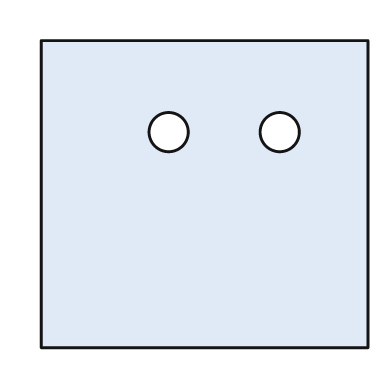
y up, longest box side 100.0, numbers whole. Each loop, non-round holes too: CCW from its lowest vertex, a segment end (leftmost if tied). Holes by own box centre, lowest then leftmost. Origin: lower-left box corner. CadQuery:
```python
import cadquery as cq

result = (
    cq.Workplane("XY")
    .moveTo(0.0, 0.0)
    .lineTo(100.0, 0.0)
    .lineTo(100.0, 94.0)
    .lineTo(0.0, 94.0)
    .close()
    .moveTo(39.0, 66.0)
    .circle(6.0)
    .moveTo(73.0, 66.0)
    .circle(6.0)
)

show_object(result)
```